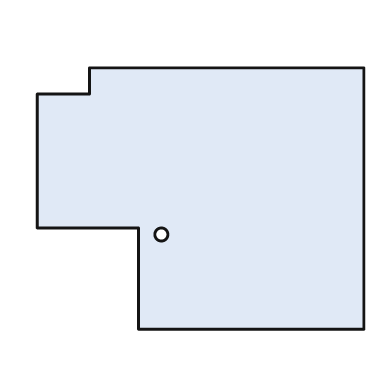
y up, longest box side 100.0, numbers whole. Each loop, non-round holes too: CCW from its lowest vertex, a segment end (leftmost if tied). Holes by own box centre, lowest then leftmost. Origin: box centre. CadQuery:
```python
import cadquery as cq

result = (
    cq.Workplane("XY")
    .moveTo(-19.0, -40.0)
    .lineTo(50.0, -40.0)
    .lineTo(50.0, 40.0)
    .lineTo(-34.0, 40.0)
    .lineTo(-34.0, 32.0)
    .lineTo(-50.0, 32.0)
    .lineTo(-50.0, -9.0)
    .lineTo(-19.0, -9.0)
    .close()
    .moveTo(-12.0, -11.0)
    .circle(2.0)
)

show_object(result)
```